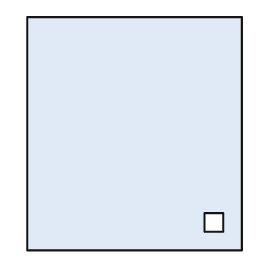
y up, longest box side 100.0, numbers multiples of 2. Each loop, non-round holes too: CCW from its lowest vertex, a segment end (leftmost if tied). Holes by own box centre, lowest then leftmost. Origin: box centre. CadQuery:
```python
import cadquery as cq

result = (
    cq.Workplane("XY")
    .moveTo(-46.0, -50.0)
    .lineTo(46.0, -50.0)
    .lineTo(46.0, 50.0)
    .lineTo(-46.0, 50.0)
    .close()
    .moveTo(30.0, -42.0)
    .lineTo(38.0, -42.0)
    .lineTo(38.0, -34.0)
    .lineTo(30.0, -34.0)
    .close()
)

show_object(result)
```